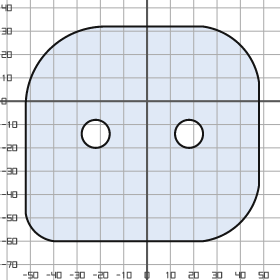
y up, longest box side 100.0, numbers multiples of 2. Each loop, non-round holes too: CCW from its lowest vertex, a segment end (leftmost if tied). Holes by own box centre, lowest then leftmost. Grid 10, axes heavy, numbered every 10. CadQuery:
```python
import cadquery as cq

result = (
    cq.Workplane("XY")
    .moveTo(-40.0, -60.0)
    .lineTo(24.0, -60.0)
    .threePointArc((40.0, -52.0), (48.0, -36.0))
    .lineTo(48.0, 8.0)
    .threePointArc((40.0, 24.0), (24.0, 32.0))
    .lineTo(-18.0, 32.0)
    .threePointArc((-42.0, 22.0), (-52.0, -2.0))
    .lineTo(-52.0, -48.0)
    .threePointArc((-48.0, -56.0), (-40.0, -60.0))
    .close()
    .moveTo(-22.0, -14.0)
    .circle(6.0)
    .moveTo(18.0, -14.0)
    .circle(6.0)
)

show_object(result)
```